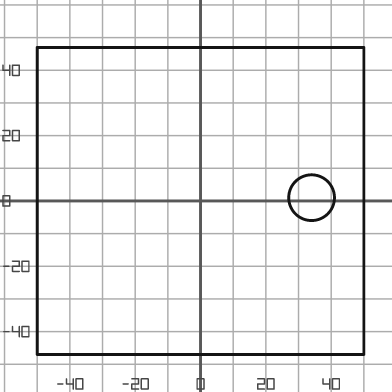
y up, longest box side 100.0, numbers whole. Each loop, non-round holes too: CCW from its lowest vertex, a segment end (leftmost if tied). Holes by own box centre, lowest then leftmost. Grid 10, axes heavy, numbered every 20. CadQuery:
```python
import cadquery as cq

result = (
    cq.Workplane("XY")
    .moveTo(-50.0, -47.0)
    .lineTo(50.0, -47.0)
    .lineTo(50.0, 47.0)
    .lineTo(-50.0, 47.0)
    .close()
    .moveTo(34.0, 1.0)
    .circle(7.0)
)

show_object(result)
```